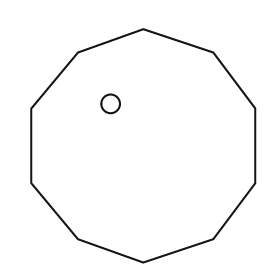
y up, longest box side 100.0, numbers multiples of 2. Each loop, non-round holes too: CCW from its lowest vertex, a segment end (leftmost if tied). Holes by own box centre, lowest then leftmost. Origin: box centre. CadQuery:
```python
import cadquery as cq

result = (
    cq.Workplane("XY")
    .moveTo(0.0, -50.0)
    .lineTo(30.0, -40.0)
    .lineTo(48.0, -16.0)
    .lineTo(48.0, 16.0)
    .lineTo(30.0, 40.0)
    .lineTo(0.0, 50.0)
    .lineTo(-28.0, 40.0)
    .lineTo(-48.0, 16.0)
    .lineTo(-48.0, -16.0)
    .lineTo(-28.0, -40.0)
    .close()
    .moveTo(-14.0, 18.0)
    .circle(4.0)
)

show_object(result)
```